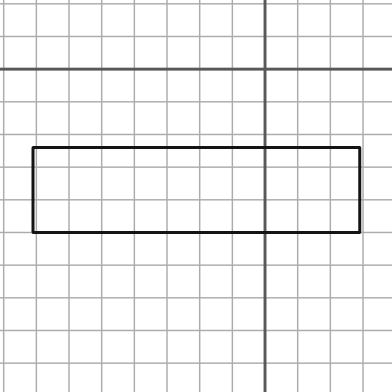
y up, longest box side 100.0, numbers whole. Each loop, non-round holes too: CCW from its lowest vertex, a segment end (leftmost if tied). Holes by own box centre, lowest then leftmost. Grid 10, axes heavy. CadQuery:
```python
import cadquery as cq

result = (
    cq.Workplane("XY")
    .moveTo(-71.0, -50.0)
    .lineTo(29.0, -50.0)
    .lineTo(29.0, -24.0)
    .lineTo(-71.0, -24.0)
    .close()
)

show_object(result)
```